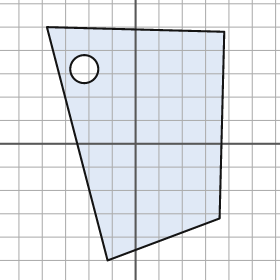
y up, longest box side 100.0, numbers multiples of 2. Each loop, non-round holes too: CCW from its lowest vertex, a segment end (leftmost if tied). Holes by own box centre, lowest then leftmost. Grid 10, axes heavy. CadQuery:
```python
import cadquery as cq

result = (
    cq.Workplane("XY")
    .moveTo(-12.0, -50.0)
    .lineTo(36.0, -32.0)
    .lineTo(38.0, 48.0)
    .lineTo(-38.0, 50.0)
    .close()
    .moveTo(-22.0, 32.0)
    .circle(6.0)
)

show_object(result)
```